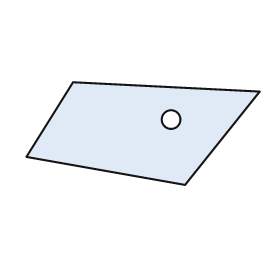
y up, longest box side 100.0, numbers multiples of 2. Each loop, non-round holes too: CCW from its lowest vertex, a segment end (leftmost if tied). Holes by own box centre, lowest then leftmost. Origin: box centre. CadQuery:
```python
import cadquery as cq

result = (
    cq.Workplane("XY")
    .moveTo(18.0, -22.0)
    .lineTo(50.0, 18.0)
    .lineTo(-30.0, 22.0)
    .lineTo(-50.0, -10.0)
    .close()
    .moveTo(12.0, 6.0)
    .circle(4.0)
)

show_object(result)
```